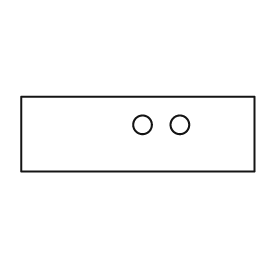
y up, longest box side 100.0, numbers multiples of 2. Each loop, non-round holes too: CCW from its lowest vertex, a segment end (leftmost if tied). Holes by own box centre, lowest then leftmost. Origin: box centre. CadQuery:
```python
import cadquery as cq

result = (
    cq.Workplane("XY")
    .moveTo(-50.0, -16.0)
    .lineTo(50.0, -16.0)
    .lineTo(50.0, 16.0)
    .lineTo(-50.0, 16.0)
    .close()
    .moveTo(2.0, 4.0)
    .circle(4.0)
    .moveTo(18.0, 4.0)
    .circle(4.0)
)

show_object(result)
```